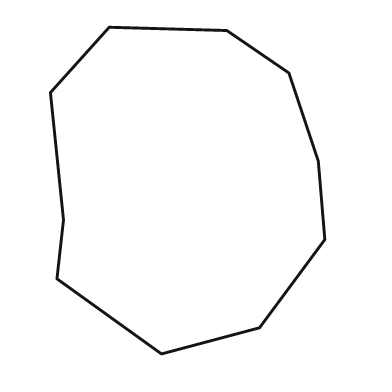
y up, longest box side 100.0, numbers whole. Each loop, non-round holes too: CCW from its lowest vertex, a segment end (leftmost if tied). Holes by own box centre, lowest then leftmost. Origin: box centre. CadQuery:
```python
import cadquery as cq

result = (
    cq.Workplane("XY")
    .moveTo(-8.0, -50.0)
    .lineTo(22.0, -42.0)
    .lineTo(42.0, -15.0)
    .lineTo(40.0, 9.0)
    .lineTo(31.0, 36.0)
    .lineTo(12.0, 49.0)
    .lineTo(-24.0, 50.0)
    .lineTo(-42.0, 30.0)
    .lineTo(-38.0, -9.0)
    .lineTo(-40.0, -27.0)
    .close()
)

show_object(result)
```